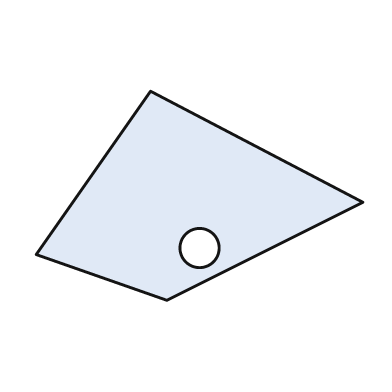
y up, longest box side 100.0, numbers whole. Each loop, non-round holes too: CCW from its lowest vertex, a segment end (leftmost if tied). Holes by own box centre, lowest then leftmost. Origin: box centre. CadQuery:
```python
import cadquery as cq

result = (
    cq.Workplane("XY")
    .moveTo(-10.0, -32.0)
    .lineTo(50.0, -2.0)
    .lineTo(-15.0, 32.0)
    .lineTo(-50.0, -18.0)
    .close()
    .moveTo(0.0, -16.0)
    .circle(6.0)
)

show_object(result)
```